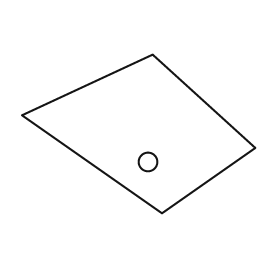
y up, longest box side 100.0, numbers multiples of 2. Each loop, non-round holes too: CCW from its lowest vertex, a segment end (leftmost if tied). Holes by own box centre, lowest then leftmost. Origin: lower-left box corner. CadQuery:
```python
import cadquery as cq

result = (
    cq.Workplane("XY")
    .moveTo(60.0, 0.0)
    .lineTo(100.0, 28.0)
    .lineTo(56.0, 68.0)
    .lineTo(0.0, 42.0)
    .close()
    .moveTo(54.0, 22.0)
    .circle(4.0)
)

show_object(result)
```